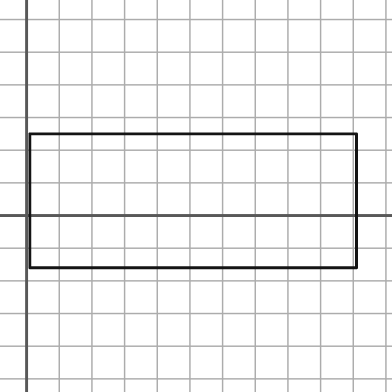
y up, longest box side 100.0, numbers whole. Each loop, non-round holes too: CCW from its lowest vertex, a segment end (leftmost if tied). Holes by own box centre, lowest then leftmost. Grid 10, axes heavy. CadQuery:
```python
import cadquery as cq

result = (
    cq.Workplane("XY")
    .moveTo(1.0, -16.0)
    .lineTo(101.0, -16.0)
    .lineTo(101.0, 25.0)
    .lineTo(1.0, 25.0)
    .close()
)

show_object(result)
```